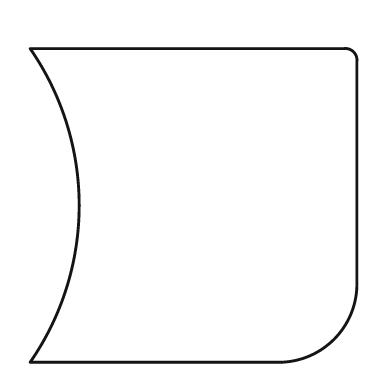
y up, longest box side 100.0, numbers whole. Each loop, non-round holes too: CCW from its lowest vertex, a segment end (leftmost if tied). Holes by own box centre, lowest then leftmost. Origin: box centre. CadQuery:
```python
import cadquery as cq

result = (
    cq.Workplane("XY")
    .moveTo(-50.0, -48.0)
    .lineTo(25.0, -48.0)
    .threePointArc((43.0, -41.0), (50.0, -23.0))
    .lineTo(50.0, 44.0)
    .threePointArc((49.0, 47.0), (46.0, 48.0))
    .lineTo(-50.0, 48.0)
    .threePointArc((-35.0, 0.0), (-50.0, -48.0))
    .close()
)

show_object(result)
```